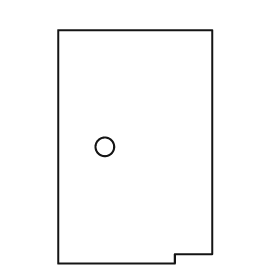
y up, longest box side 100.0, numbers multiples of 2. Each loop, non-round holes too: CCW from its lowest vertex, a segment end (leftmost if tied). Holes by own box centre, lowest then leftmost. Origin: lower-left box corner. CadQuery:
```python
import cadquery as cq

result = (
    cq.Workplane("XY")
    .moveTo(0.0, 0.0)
    .lineTo(50.0, 0.0)
    .lineTo(50.0, 4.0)
    .lineTo(66.0, 4.0)
    .lineTo(66.0, 100.0)
    .lineTo(0.0, 100.0)
    .close()
    .moveTo(20.0, 50.0)
    .circle(4.0)
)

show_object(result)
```